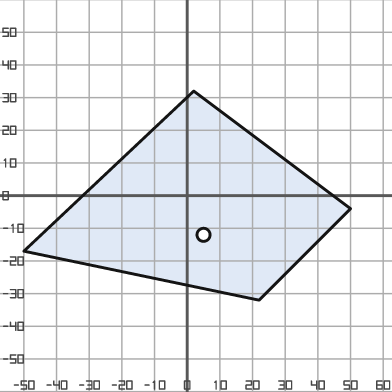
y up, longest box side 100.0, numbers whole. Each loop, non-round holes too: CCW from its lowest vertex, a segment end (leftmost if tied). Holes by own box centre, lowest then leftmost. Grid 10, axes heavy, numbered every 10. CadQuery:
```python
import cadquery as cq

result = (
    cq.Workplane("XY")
    .moveTo(22.0, -32.0)
    .lineTo(50.0, -4.0)
    .lineTo(2.0, 32.0)
    .lineTo(-50.0, -17.0)
    .close()
    .moveTo(5.0, -12.0)
    .circle(2.0)
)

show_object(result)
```